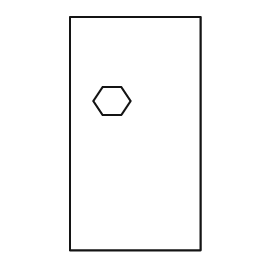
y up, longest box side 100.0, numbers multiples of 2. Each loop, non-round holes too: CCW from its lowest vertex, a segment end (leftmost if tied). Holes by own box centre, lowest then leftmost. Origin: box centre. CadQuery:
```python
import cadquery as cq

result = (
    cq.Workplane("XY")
    .moveTo(-28.0, -50.0)
    .lineTo(28.0, -50.0)
    .lineTo(28.0, 50.0)
    .lineTo(-28.0, 50.0)
    .close()
    .moveTo(-14.0, 8.0)
    .lineTo(-6.0, 8.0)
    .lineTo(-2.0, 14.0)
    .lineTo(-6.0, 20.0)
    .lineTo(-14.0, 20.0)
    .lineTo(-18.0, 14.0)
    .close()
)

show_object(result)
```